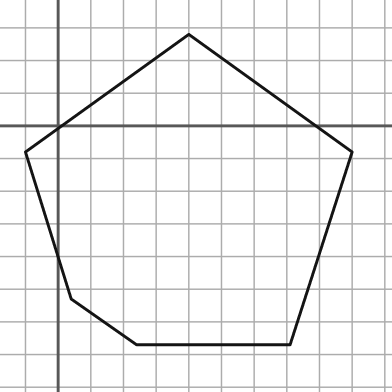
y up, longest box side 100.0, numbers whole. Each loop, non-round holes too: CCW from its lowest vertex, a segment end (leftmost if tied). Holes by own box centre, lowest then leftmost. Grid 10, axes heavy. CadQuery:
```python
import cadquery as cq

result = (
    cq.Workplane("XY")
    .moveTo(24.0, -67.0)
    .lineTo(71.0, -67.0)
    .lineTo(90.0, -8.0)
    .lineTo(40.0, 28.0)
    .lineTo(-10.0, -8.0)
    .lineTo(4.0, -53.0)
    .close()
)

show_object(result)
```